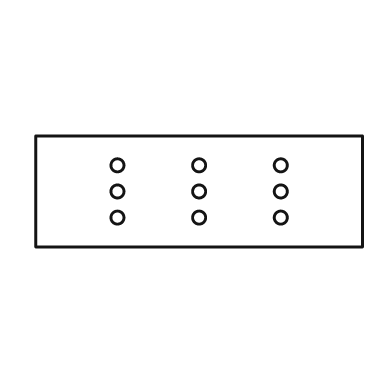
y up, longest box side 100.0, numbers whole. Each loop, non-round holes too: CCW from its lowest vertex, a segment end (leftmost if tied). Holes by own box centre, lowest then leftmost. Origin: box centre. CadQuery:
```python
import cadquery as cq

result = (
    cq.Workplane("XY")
    .moveTo(-50.0, -17.0)
    .lineTo(50.0, -17.0)
    .lineTo(50.0, 17.0)
    .lineTo(-50.0, 17.0)
    .close()
    .moveTo(-25.0, -8.0)
    .circle(2.0)
    .moveTo(0.0, -8.0)
    .circle(2.0)
    .moveTo(25.0, -8.0)
    .circle(2.0)
    .moveTo(-25.0, 0.0)
    .circle(2.0)
    .moveTo(0.0, 0.0)
    .circle(2.0)
    .moveTo(25.0, 0.0)
    .circle(2.0)
    .moveTo(-25.0, 8.0)
    .circle(2.0)
    .moveTo(0.0, 8.0)
    .circle(2.0)
    .moveTo(25.0, 8.0)
    .circle(2.0)
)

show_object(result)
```